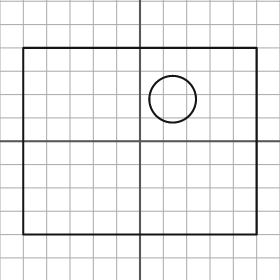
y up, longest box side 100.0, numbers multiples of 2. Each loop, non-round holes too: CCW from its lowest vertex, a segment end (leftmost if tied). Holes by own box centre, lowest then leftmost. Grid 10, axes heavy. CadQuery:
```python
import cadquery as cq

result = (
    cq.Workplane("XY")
    .moveTo(-50.0, -40.0)
    .lineTo(50.0, -40.0)
    .lineTo(50.0, 40.0)
    .lineTo(-50.0, 40.0)
    .close()
    .moveTo(14.0, 18.0)
    .circle(10.0)
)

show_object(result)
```